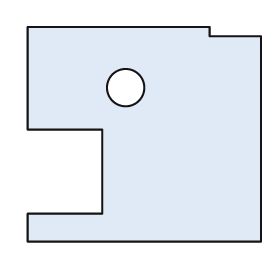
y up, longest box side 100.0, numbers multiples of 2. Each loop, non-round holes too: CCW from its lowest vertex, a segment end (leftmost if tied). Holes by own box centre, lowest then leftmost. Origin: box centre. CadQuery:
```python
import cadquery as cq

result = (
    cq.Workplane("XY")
    .moveTo(-50.0, -46.0)
    .lineTo(50.0, -46.0)
    .lineTo(50.0, 42.0)
    .lineTo(28.0, 42.0)
    .lineTo(28.0, 46.0)
    .lineTo(-50.0, 46.0)
    .lineTo(-50.0, 2.0)
    .lineTo(-18.0, 2.0)
    .lineTo(-18.0, -34.0)
    .lineTo(-50.0, -34.0)
    .close()
    .moveTo(-8.0, 20.0)
    .circle(8.0)
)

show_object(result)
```